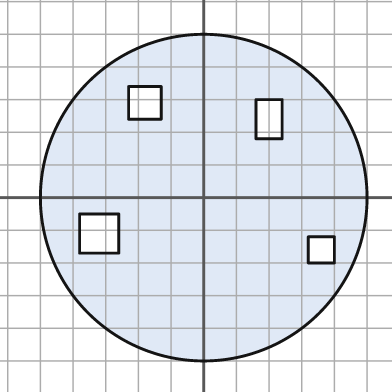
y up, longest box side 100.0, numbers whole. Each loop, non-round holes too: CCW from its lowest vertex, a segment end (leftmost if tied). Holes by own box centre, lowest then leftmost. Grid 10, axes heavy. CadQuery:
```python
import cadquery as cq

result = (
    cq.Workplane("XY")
    .moveTo(0.0, 0.0)
    .circle(50.0)
    .moveTo(32.0, -20.0)
    .lineTo(40.0, -20.0)
    .lineTo(40.0, -12.0)
    .lineTo(32.0, -12.0)
    .close()
    .moveTo(-38.0, -17.0)
    .lineTo(-26.0, -17.0)
    .lineTo(-26.0, -5.0)
    .lineTo(-38.0, -5.0)
    .close()
    .moveTo(16.0, 18.0)
    .lineTo(24.0, 18.0)
    .lineTo(24.0, 30.0)
    .lineTo(16.0, 30.0)
    .close()
    .moveTo(-23.0, 24.0)
    .lineTo(-13.0, 24.0)
    .lineTo(-13.0, 34.0)
    .lineTo(-23.0, 34.0)
    .close()
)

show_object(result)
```